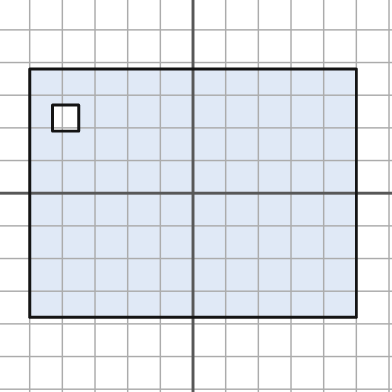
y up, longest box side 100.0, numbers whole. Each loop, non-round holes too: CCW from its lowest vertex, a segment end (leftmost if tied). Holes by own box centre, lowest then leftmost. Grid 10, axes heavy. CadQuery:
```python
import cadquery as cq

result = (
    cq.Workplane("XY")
    .moveTo(-50.0, -38.0)
    .lineTo(50.0, -38.0)
    .lineTo(50.0, 38.0)
    .lineTo(-50.0, 38.0)
    .close()
    .moveTo(-43.0, 19.0)
    .lineTo(-35.0, 19.0)
    .lineTo(-35.0, 27.0)
    .lineTo(-43.0, 27.0)
    .close()
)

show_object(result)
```